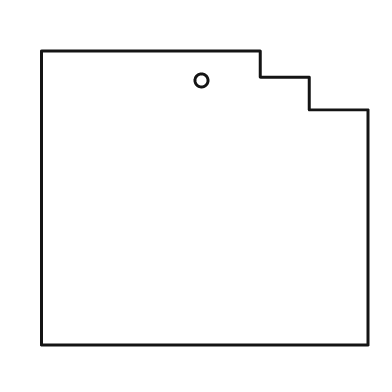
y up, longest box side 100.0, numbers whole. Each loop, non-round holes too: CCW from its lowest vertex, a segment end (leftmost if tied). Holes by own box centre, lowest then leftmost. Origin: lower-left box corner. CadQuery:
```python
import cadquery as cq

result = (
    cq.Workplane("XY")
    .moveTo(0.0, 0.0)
    .lineTo(100.0, 0.0)
    .lineTo(100.0, 72.0)
    .lineTo(82.0, 72.0)
    .lineTo(82.0, 82.0)
    .lineTo(67.0, 82.0)
    .lineTo(67.0, 90.0)
    .lineTo(0.0, 90.0)
    .close()
    .moveTo(49.0, 81.0)
    .circle(2.0)
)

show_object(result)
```